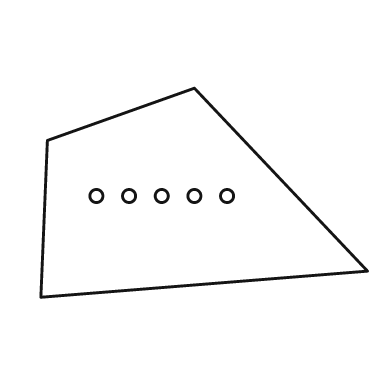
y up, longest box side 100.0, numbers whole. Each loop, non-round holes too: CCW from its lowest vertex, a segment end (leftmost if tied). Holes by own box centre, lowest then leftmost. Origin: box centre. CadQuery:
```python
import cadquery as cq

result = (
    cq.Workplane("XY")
    .moveTo(-50.0, -32.0)
    .lineTo(50.0, -24.0)
    .lineTo(-3.0, 32.0)
    .lineTo(-48.0, 16.0)
    .close()
    .moveTo(-33.0, -1.0)
    .circle(2.0)
    .moveTo(-23.0, -1.0)
    .circle(2.0)
    .moveTo(-13.0, -1.0)
    .circle(2.0)
    .moveTo(-3.0, -1.0)
    .circle(2.0)
    .moveTo(7.0, -1.0)
    .circle(2.0)
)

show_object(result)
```